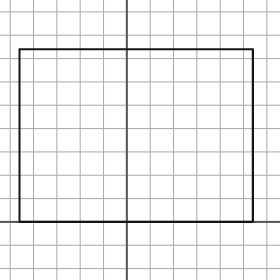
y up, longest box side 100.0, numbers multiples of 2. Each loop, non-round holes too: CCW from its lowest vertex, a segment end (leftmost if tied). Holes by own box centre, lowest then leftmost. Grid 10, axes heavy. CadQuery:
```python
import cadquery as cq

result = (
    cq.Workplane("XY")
    .moveTo(-46.0, 0.0)
    .lineTo(54.0, 0.0)
    .lineTo(54.0, 74.0)
    .lineTo(-46.0, 74.0)
    .close()
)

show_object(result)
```